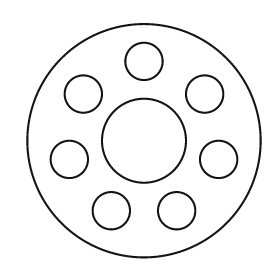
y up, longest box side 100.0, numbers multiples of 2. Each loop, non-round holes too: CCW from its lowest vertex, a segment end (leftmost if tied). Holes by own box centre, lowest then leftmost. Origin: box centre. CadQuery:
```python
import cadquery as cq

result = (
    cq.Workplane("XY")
    .moveTo(0.0, 0.0)
    .circle(50.0)
    .moveTo(-14.0, -30.0)
    .circle(8.0)
    .moveTo(14.0, -30.0)
    .circle(8.0)
    .moveTo(-32.0, -8.0)
    .circle(8.0)
    .moveTo(32.0, -8.0)
    .circle(8.0)
    .moveTo(0.0, 0.0)
    .circle(18.0)
    .moveTo(-26.0, 20.0)
    .circle(8.0)
    .moveTo(26.0, 20.0)
    .circle(8.0)
    .moveTo(0.0, 34.0)
    .circle(8.0)
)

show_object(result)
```